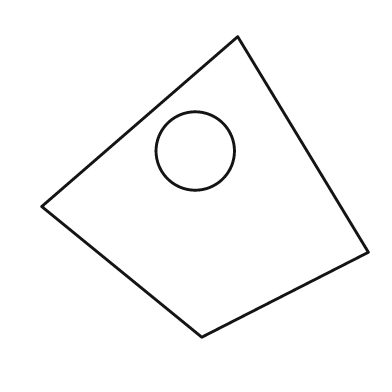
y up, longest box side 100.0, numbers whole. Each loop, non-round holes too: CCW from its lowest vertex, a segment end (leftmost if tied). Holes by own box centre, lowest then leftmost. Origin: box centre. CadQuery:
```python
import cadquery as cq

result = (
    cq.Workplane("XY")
    .moveTo(-1.0, -46.0)
    .lineTo(50.0, -20.0)
    .lineTo(10.0, 46.0)
    .lineTo(-50.0, -6.0)
    .close()
    .moveTo(-3.0, 11.0)
    .circle(12.0)
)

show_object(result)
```